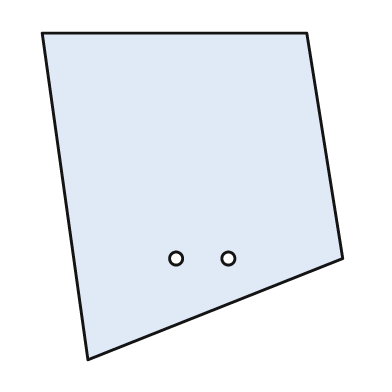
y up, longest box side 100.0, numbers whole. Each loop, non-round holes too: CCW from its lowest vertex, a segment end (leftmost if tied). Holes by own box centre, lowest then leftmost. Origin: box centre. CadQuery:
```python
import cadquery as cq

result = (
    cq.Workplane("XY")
    .moveTo(-32.0, -50.0)
    .lineTo(46.0, -19.0)
    .lineTo(35.0, 50.0)
    .lineTo(-46.0, 50.0)
    .close()
    .moveTo(-5.0, -19.0)
    .circle(2.0)
    .moveTo(11.0, -19.0)
    .circle(2.0)
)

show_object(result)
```